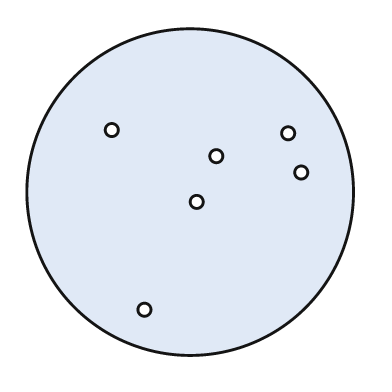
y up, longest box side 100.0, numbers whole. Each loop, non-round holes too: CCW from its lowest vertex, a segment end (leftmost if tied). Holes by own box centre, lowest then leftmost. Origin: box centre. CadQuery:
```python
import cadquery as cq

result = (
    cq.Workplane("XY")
    .moveTo(0.0, 0.0)
    .circle(50.0)
    .moveTo(-14.0, -36.0)
    .circle(2.0)
    .moveTo(2.0, -3.0)
    .circle(2.0)
    .moveTo(34.0, 6.0)
    .circle(2.0)
    .moveTo(8.0, 11.0)
    .circle(2.0)
    .moveTo(30.0, 18.0)
    .circle(2.0)
    .moveTo(-24.0, 19.0)
    .circle(2.0)
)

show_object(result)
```